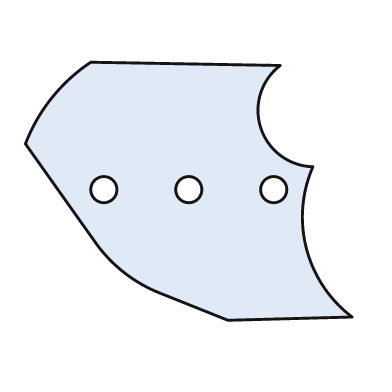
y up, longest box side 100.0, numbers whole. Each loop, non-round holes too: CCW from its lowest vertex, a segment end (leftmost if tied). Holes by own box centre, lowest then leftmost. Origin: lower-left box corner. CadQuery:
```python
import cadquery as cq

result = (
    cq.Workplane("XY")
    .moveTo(62.0, 0.0)
    .lineTo(100.0, 1.0)
    .threePointArc((86.0, 22.0), (88.0, 47.0))
    .threePointArc((72.0, 59.0), (78.0, 78.0))
    .lineTo(20.0, 79.0)
    .threePointArc((8.0, 68.0), (0.0, 54.0))
    .lineTo(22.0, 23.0)
    .threePointArc((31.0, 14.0), (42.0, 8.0))
    .close()
    .moveTo(24.0, 40.0)
    .circle(4.0)
    .moveTo(50.0, 40.0)
    .circle(4.0)
    .moveTo(76.0, 40.0)
    .circle(4.0)
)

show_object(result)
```